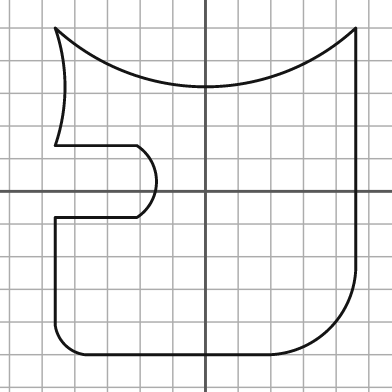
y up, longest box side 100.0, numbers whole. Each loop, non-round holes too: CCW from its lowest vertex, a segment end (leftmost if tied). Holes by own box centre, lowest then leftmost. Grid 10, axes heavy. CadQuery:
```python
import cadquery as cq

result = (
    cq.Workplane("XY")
    .moveTo(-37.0, -50.0)
    .lineTo(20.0, -50.0)
    .threePointArc((38.0, -42.0), (46.0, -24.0))
    .lineTo(46.0, 50.0)
    .threePointArc((0.0, 32.0), (-46.0, 50.0))
    .threePointArc((-43.0, 32.0), (-46.0, 14.0))
    .lineTo(-21.0, 14.0)
    .threePointArc((-15.0, 3.0), (-21.0, -8.0))
    .lineTo(-46.0, -8.0)
    .lineTo(-46.0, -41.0)
    .threePointArc((-43.0, -47.0), (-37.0, -50.0))
    .close()
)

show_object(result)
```